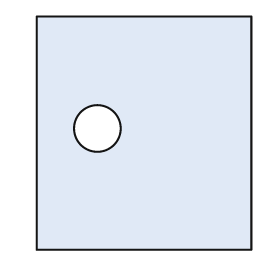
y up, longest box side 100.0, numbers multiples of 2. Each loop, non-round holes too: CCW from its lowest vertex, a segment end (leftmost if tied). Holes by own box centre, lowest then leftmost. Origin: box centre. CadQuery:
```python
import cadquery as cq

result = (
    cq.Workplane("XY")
    .moveTo(-46.0, -50.0)
    .lineTo(46.0, -50.0)
    .lineTo(46.0, 50.0)
    .lineTo(-46.0, 50.0)
    .close()
    .moveTo(-20.0, 2.0)
    .circle(10.0)
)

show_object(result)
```